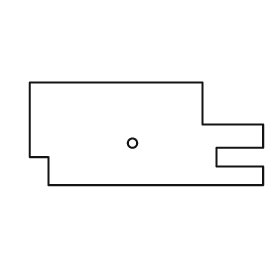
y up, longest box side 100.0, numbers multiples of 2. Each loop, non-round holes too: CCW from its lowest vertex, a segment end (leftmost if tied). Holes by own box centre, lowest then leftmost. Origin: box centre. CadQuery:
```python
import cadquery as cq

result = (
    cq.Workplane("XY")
    .moveTo(-42.0, -22.0)
    .lineTo(50.0, -22.0)
    .lineTo(50.0, -14.0)
    .lineTo(30.0, -14.0)
    .lineTo(30.0, -6.0)
    .lineTo(50.0, -6.0)
    .lineTo(50.0, 4.0)
    .lineTo(24.0, 4.0)
    .lineTo(24.0, 22.0)
    .lineTo(-50.0, 22.0)
    .lineTo(-50.0, -10.0)
    .lineTo(-42.0, -10.0)
    .close()
    .moveTo(-6.0, -4.0)
    .circle(2.0)
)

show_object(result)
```